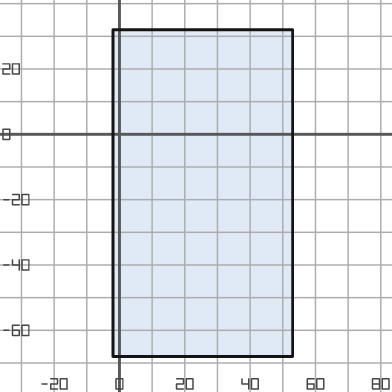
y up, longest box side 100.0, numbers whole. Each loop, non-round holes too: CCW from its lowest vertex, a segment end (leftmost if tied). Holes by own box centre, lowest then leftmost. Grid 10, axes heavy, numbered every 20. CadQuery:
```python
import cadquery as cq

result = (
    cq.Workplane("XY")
    .moveTo(-2.0, -68.0)
    .lineTo(53.0, -68.0)
    .lineTo(53.0, 32.0)
    .lineTo(-2.0, 32.0)
    .close()
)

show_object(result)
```